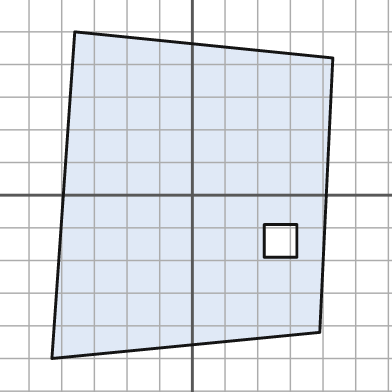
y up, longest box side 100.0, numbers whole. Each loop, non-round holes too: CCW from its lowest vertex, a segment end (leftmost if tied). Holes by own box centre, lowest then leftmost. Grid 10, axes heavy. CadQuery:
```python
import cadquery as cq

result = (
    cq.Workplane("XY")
    .moveTo(-43.0, -50.0)
    .lineTo(39.0, -42.0)
    .lineTo(43.0, 42.0)
    .lineTo(-36.0, 50.0)
    .close()
    .moveTo(22.0, -19.0)
    .lineTo(32.0, -19.0)
    .lineTo(32.0, -9.0)
    .lineTo(22.0, -9.0)
    .close()
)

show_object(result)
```